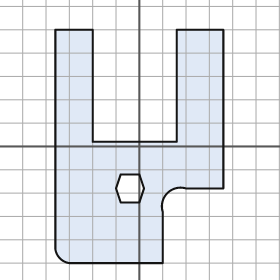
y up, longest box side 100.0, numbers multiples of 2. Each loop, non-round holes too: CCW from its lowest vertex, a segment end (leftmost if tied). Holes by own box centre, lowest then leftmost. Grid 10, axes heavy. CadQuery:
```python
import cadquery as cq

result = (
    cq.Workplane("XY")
    .moveTo(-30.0, -50.0)
    .lineTo(10.0, -50.0)
    .lineTo(10.0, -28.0)
    .threePointArc((12.0, -20.0), (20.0, -18.0))
    .lineTo(36.0, -18.0)
    .lineTo(36.0, 50.0)
    .lineTo(16.0, 50.0)
    .lineTo(16.0, 2.0)
    .lineTo(-20.0, 2.0)
    .lineTo(-20.0, 50.0)
    .lineTo(-36.0, 50.0)
    .lineTo(-36.0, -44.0)
    .threePointArc((-34.0, -48.0), (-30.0, -50.0))
    .close()
    .moveTo(-8.0, -24.0)
    .lineTo(0.0, -24.0)
    .lineTo(2.0, -18.0)
    .lineTo(0.0, -12.0)
    .lineTo(-8.0, -12.0)
    .lineTo(-10.0, -18.0)
    .close()
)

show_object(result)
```